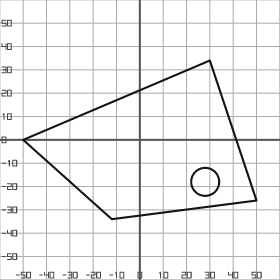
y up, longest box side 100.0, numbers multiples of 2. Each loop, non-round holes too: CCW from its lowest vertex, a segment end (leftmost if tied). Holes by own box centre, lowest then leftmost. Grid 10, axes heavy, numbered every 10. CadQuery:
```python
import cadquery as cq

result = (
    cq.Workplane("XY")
    .moveTo(-12.0, -34.0)
    .lineTo(50.0, -26.0)
    .lineTo(30.0, 34.0)
    .lineTo(-50.0, 0.0)
    .close()
    .moveTo(28.0, -18.0)
    .circle(6.0)
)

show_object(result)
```